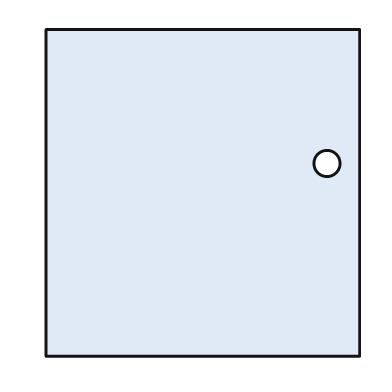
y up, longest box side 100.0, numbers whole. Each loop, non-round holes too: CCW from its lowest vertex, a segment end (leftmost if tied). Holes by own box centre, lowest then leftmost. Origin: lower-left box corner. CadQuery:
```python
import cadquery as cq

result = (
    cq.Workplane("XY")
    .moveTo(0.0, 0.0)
    .lineTo(96.0, 0.0)
    .lineTo(96.0, 100.0)
    .lineTo(0.0, 100.0)
    .close()
    .moveTo(86.0, 59.0)
    .circle(4.0)
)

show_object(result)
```